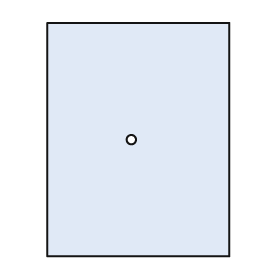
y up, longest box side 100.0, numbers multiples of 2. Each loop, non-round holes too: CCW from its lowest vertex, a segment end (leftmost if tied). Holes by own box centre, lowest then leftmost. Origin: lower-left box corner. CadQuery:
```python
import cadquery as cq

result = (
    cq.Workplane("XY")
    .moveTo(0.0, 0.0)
    .lineTo(78.0, 0.0)
    .lineTo(78.0, 100.0)
    .lineTo(0.0, 100.0)
    .close()
    .moveTo(36.0, 50.0)
    .circle(2.0)
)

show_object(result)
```